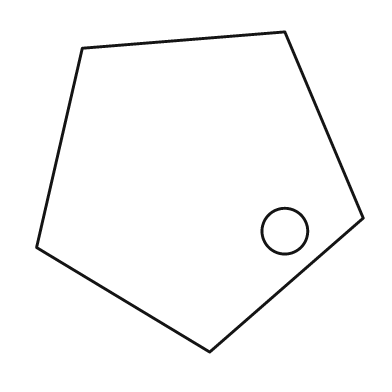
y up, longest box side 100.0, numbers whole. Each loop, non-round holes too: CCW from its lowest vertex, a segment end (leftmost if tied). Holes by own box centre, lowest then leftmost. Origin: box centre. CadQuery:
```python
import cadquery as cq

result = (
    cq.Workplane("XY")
    .moveTo(3.0, -49.0)
    .lineTo(50.0, -8.0)
    .lineTo(26.0, 49.0)
    .lineTo(-36.0, 44.0)
    .lineTo(-50.0, -17.0)
    .close()
    .moveTo(26.0, -12.0)
    .circle(7.0)
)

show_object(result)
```